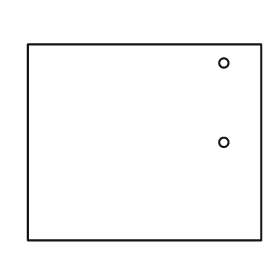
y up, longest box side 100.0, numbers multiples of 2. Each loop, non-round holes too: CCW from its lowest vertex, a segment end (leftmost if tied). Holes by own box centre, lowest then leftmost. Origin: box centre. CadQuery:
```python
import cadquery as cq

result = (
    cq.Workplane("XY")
    .moveTo(-50.0, -42.0)
    .lineTo(50.0, -42.0)
    .lineTo(50.0, 42.0)
    .lineTo(-50.0, 42.0)
    .close()
    .moveTo(34.0, 0.0)
    .circle(2.0)
    .moveTo(34.0, 34.0)
    .circle(2.0)
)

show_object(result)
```